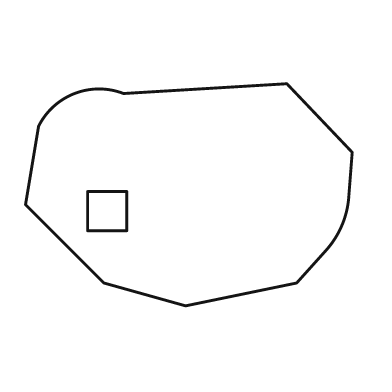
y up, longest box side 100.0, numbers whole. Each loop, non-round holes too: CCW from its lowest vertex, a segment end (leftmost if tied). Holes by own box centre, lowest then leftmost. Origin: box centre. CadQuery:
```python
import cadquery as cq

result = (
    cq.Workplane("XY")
    .moveTo(-1.0, -34.0)
    .lineTo(33.0, -27.0)
    .lineTo(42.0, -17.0)
    .threePointArc((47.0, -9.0), (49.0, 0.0))
    .lineTo(50.0, 13.0)
    .lineTo(30.0, 34.0)
    .lineTo(-20.0, 31.0)
    .threePointArc((-35.0, 31.0), (-46.0, 21.0))
    .lineTo(-50.0, -3.0)
    .lineTo(-26.0, -27.0)
    .close()
    .moveTo(-31.0, -11.0)
    .lineTo(-19.0, -11.0)
    .lineTo(-19.0, 1.0)
    .lineTo(-31.0, 1.0)
    .close()
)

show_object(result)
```